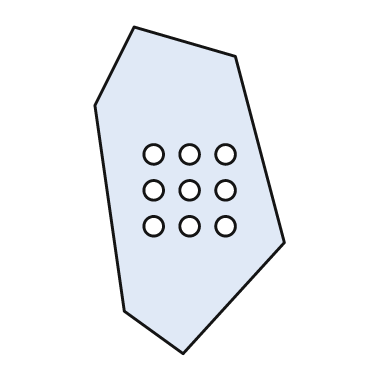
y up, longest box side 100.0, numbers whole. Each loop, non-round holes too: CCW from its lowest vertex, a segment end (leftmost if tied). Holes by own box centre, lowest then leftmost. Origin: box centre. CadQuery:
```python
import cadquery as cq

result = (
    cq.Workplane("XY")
    .moveTo(-2.0, -50.0)
    .lineTo(29.0, -16.0)
    .lineTo(14.0, 41.0)
    .lineTo(-17.0, 50.0)
    .lineTo(-29.0, 26.0)
    .lineTo(-20.0, -37.0)
    .close()
    .moveTo(-11.0, -11.0)
    .circle(3.0)
    .moveTo(0.0, -11.0)
    .circle(3.0)
    .moveTo(11.0, -11.0)
    .circle(3.0)
    .moveTo(-11.0, 0.0)
    .circle(3.0)
    .moveTo(0.0, 0.0)
    .circle(3.0)
    .moveTo(11.0, 0.0)
    .circle(3.0)
    .moveTo(-11.0, 11.0)
    .circle(3.0)
    .moveTo(0.0, 11.0)
    .circle(3.0)
    .moveTo(11.0, 11.0)
    .circle(3.0)
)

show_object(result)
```